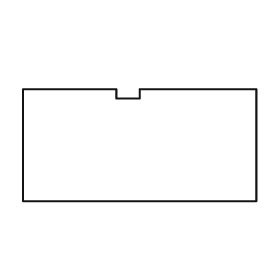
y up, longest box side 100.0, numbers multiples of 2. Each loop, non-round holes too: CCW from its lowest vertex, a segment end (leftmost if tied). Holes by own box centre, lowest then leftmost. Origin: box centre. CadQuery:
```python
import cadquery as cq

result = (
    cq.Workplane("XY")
    .moveTo(-50.0, -24.0)
    .lineTo(50.0, -24.0)
    .lineTo(50.0, 24.0)
    .lineTo(0.0, 24.0)
    .lineTo(0.0, 20.0)
    .lineTo(-10.0, 20.0)
    .lineTo(-10.0, 24.0)
    .lineTo(-50.0, 24.0)
    .close()
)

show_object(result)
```